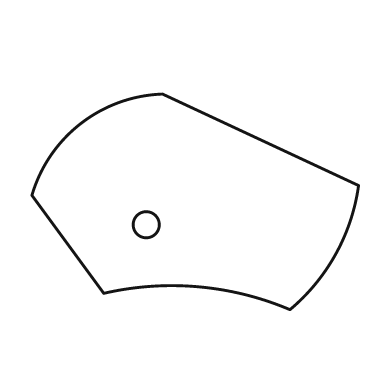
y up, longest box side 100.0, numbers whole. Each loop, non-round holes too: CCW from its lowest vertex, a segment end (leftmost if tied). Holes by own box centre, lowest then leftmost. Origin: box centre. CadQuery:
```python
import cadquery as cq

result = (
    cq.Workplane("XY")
    .moveTo(29.0, -33.0)
    .threePointArc((43.0, -16.0), (50.0, 5.0))
    .lineTo(-10.0, 33.0)
    .threePointArc((-35.0, 24.0), (-50.0, 2.0))
    .lineTo(-28.0, -28.0)
    .threePointArc((1.0, -26.0), (29.0, -33.0))
    .close()
    .moveTo(-15.0, -7.0)
    .circle(4.0)
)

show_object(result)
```